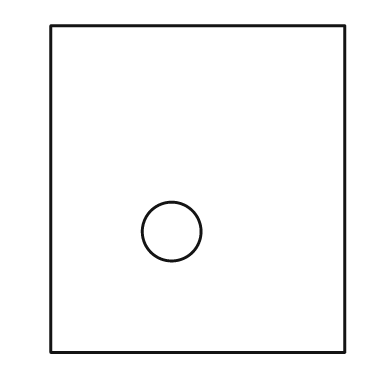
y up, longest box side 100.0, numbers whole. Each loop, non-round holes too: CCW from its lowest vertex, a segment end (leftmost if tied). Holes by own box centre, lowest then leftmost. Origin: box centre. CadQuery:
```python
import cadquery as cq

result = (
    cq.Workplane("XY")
    .moveTo(-45.0, -50.0)
    .lineTo(45.0, -50.0)
    .lineTo(45.0, 50.0)
    .lineTo(-45.0, 50.0)
    .close()
    .moveTo(-8.0, -13.0)
    .circle(9.0)
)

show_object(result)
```